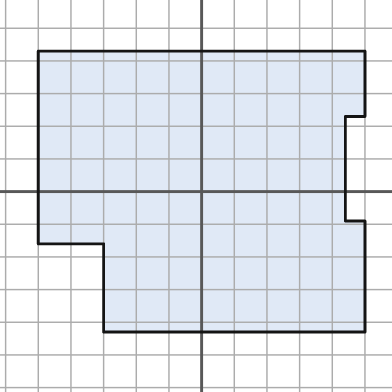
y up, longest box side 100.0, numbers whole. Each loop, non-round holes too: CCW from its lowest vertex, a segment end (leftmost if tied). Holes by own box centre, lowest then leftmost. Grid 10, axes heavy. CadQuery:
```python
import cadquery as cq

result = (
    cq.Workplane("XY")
    .moveTo(-30.0, -43.0)
    .lineTo(50.0, -43.0)
    .lineTo(50.0, -9.0)
    .lineTo(44.0, -9.0)
    .lineTo(44.0, 23.0)
    .lineTo(50.0, 23.0)
    .lineTo(50.0, 43.0)
    .lineTo(-50.0, 43.0)
    .lineTo(-50.0, -16.0)
    .lineTo(-30.0, -16.0)
    .close()
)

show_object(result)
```